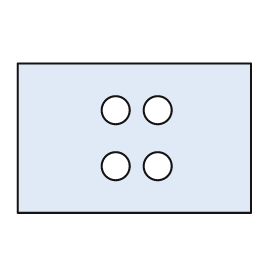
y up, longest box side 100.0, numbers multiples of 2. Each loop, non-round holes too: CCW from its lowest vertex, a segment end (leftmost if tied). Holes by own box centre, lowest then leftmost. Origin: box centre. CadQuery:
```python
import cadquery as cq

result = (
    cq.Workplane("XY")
    .moveTo(-50.0, -32.0)
    .lineTo(50.0, -32.0)
    .lineTo(50.0, 32.0)
    .lineTo(-50.0, 32.0)
    .close()
    .moveTo(-8.0, -12.0)
    .circle(6.0)
    .moveTo(10.0, -12.0)
    .circle(6.0)
    .moveTo(-8.0, 12.0)
    .circle(6.0)
    .moveTo(10.0, 12.0)
    .circle(6.0)
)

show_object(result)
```